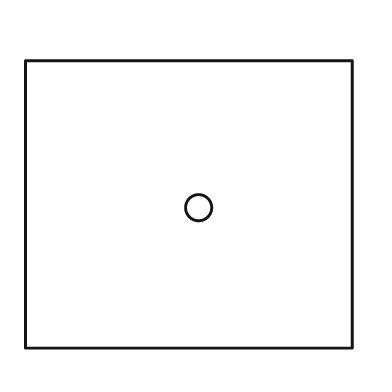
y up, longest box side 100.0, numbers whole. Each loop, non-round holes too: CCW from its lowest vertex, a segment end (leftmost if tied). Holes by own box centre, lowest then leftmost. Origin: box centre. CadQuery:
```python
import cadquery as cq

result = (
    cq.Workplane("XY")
    .moveTo(-50.0, -44.0)
    .lineTo(50.0, -44.0)
    .lineTo(50.0, 44.0)
    .lineTo(-50.0, 44.0)
    .close()
    .moveTo(3.0, -1.0)
    .circle(4.0)
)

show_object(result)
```